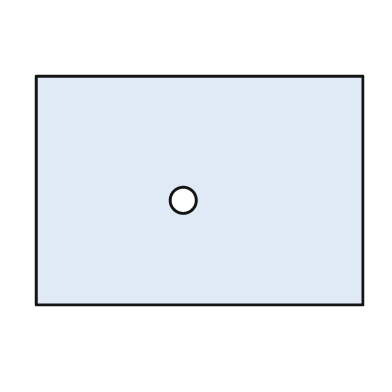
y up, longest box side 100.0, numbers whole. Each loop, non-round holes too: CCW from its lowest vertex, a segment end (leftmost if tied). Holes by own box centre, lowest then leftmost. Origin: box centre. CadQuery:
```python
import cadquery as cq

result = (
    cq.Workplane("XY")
    .moveTo(-50.0, -35.0)
    .lineTo(50.0, -35.0)
    .lineTo(50.0, 35.0)
    .lineTo(-50.0, 35.0)
    .close()
    .moveTo(-5.0, -3.0)
    .circle(4.0)
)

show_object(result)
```